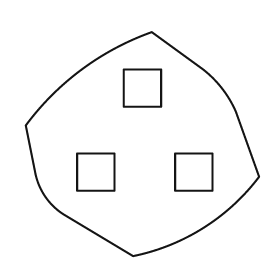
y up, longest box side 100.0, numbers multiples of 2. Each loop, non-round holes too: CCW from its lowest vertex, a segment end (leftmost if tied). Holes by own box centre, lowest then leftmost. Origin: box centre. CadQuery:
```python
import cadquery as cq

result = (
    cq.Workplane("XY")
    .moveTo(-4.0, -48.0)
    .threePointArc((26.0, -36.0), (50.0, -14.0))
    .lineTo(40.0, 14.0)
    .threePointArc((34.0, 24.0), (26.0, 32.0))
    .lineTo(4.0, 48.0)
    .threePointArc((-26.0, 32.0), (-50.0, 8.0))
    .lineTo(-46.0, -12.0)
    .threePointArc((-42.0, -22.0), (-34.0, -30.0))
    .close()
    .moveTo(-28.0, -20.0)
    .lineTo(-12.0, -20.0)
    .lineTo(-12.0, -4.0)
    .lineTo(-28.0, -4.0)
    .close()
    .moveTo(14.0, -20.0)
    .lineTo(30.0, -20.0)
    .lineTo(30.0, -4.0)
    .lineTo(14.0, -4.0)
    .close()
    .moveTo(-8.0, 16.0)
    .lineTo(8.0, 16.0)
    .lineTo(8.0, 32.0)
    .lineTo(-8.0, 32.0)
    .close()
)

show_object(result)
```